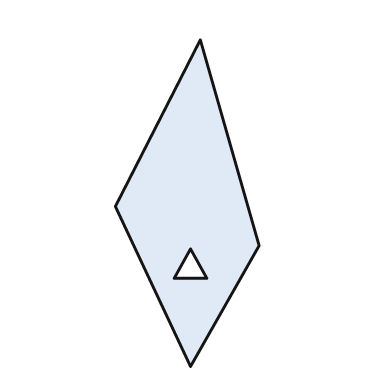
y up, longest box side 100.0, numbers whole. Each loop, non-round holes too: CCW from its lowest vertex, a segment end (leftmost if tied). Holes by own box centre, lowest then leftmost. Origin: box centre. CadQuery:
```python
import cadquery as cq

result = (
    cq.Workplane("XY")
    .moveTo(1.0, -50.0)
    .lineTo(22.0, -13.0)
    .lineTo(4.0, 50.0)
    .lineTo(-22.0, -1.0)
    .close()
    .moveTo(-4.0, -23.0)
    .lineTo(6.0, -23.0)
    .lineTo(1.0, -14.0)
    .close()
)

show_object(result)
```